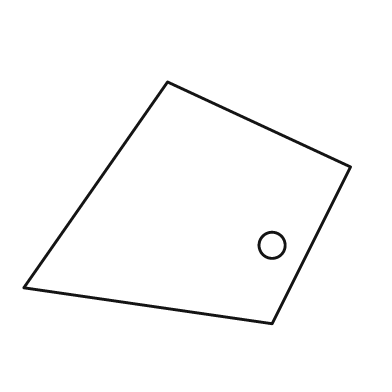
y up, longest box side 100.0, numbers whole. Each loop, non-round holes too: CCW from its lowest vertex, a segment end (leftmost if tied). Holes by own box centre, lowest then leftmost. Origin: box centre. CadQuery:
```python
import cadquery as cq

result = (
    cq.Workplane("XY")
    .moveTo(26.0, -37.0)
    .lineTo(50.0, 11.0)
    .lineTo(-6.0, 37.0)
    .lineTo(-50.0, -26.0)
    .close()
    .moveTo(26.0, -13.0)
    .circle(4.0)
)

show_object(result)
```